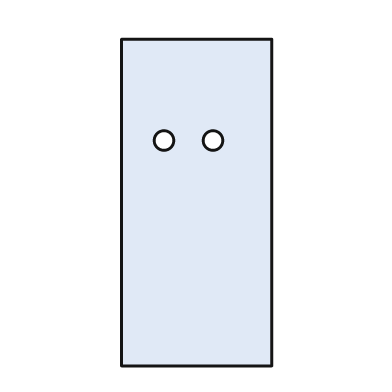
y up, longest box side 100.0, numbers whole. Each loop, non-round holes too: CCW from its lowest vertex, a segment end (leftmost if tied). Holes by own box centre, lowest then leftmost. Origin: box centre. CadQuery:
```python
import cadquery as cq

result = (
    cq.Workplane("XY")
    .moveTo(-23.0, -50.0)
    .lineTo(23.0, -50.0)
    .lineTo(23.0, 50.0)
    .lineTo(-23.0, 50.0)
    .close()
    .moveTo(-10.0, 19.0)
    .circle(3.0)
    .moveTo(5.0, 19.0)
    .circle(3.0)
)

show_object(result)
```